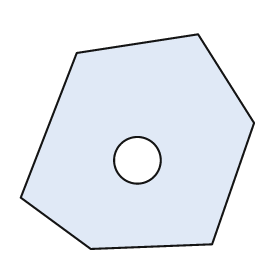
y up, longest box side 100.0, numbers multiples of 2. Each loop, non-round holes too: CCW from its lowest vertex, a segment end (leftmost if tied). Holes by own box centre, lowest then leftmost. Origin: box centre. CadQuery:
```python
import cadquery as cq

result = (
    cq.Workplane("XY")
    .moveTo(-20.0, -46.0)
    .lineTo(32.0, -44.0)
    .lineTo(50.0, 8.0)
    .lineTo(26.0, 46.0)
    .lineTo(-26.0, 38.0)
    .lineTo(-50.0, -24.0)
    .close()
    .moveTo(0.0, -8.0)
    .circle(10.0)
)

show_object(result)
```